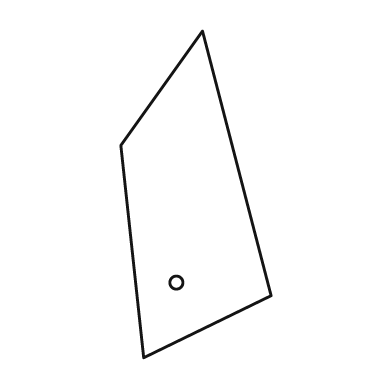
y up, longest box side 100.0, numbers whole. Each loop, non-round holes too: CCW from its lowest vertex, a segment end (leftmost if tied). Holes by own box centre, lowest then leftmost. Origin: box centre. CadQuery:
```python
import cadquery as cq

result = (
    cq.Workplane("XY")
    .moveTo(-16.0, -50.0)
    .lineTo(23.0, -31.0)
    .lineTo(2.0, 50.0)
    .lineTo(-23.0, 15.0)
    .close()
    .moveTo(-6.0, -27.0)
    .circle(2.0)
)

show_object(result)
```